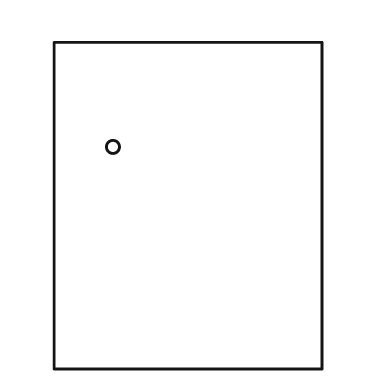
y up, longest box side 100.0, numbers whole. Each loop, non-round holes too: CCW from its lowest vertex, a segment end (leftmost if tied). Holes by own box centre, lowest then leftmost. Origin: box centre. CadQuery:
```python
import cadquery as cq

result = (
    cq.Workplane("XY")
    .moveTo(-41.0, -50.0)
    .lineTo(41.0, -50.0)
    .lineTo(41.0, 50.0)
    .lineTo(-41.0, 50.0)
    .close()
    .moveTo(-23.0, 18.0)
    .circle(2.0)
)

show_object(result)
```